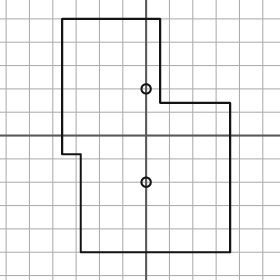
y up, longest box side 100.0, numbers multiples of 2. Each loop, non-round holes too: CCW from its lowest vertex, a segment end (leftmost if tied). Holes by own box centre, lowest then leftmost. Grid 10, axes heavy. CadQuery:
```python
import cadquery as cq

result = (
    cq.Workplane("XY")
    .moveTo(-28.0, -50.0)
    .lineTo(36.0, -50.0)
    .lineTo(36.0, 14.0)
    .lineTo(6.0, 14.0)
    .lineTo(6.0, 50.0)
    .lineTo(-36.0, 50.0)
    .lineTo(-36.0, -8.0)
    .lineTo(-28.0, -8.0)
    .close()
    .moveTo(0.0, -20.0)
    .circle(2.0)
    .moveTo(0.0, 20.0)
    .circle(2.0)
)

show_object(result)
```